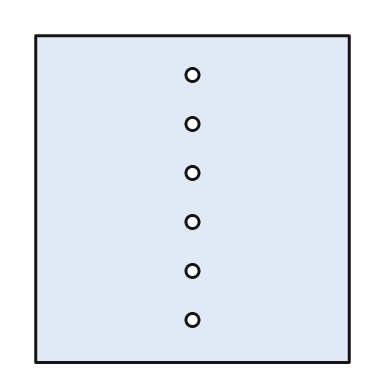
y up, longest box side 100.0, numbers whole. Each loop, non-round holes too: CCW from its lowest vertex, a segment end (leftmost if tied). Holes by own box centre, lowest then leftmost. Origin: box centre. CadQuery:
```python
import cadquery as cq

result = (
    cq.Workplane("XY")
    .moveTo(-48.0, -50.0)
    .lineTo(48.0, -50.0)
    .lineTo(48.0, 50.0)
    .lineTo(-48.0, 50.0)
    .close()
    .moveTo(0.0, -37.0)
    .circle(2.0)
    .moveTo(0.0, -22.0)
    .circle(2.0)
    .moveTo(0.0, -7.0)
    .circle(2.0)
    .moveTo(0.0, 8.0)
    .circle(2.0)
    .moveTo(0.0, 23.0)
    .circle(2.0)
    .moveTo(0.0, 38.0)
    .circle(2.0)
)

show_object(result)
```